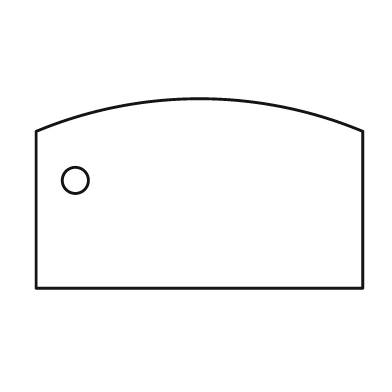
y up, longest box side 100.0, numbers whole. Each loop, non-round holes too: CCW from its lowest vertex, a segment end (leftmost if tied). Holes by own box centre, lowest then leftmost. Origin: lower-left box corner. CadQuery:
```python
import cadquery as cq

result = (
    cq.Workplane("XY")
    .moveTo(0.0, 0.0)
    .lineTo(100.0, 0.0)
    .lineTo(100.0, 48.0)
    .threePointArc((50.0, 58.0), (0.0, 48.0))
    .close()
    .moveTo(12.0, 33.0)
    .circle(4.0)
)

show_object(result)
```